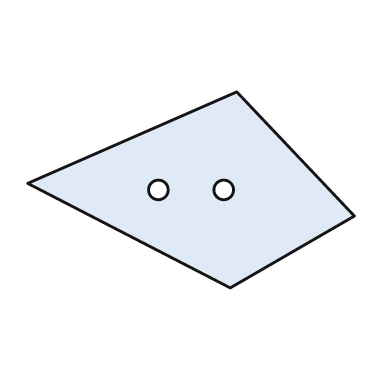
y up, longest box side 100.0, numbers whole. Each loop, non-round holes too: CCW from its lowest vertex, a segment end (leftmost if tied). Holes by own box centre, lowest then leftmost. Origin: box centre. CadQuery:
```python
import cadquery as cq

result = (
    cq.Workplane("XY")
    .moveTo(12.0, -30.0)
    .lineTo(50.0, -8.0)
    .lineTo(14.0, 30.0)
    .lineTo(-50.0, 2.0)
    .close()
    .moveTo(-10.0, 0.0)
    .circle(3.0)
    .moveTo(10.0, 0.0)
    .circle(3.0)
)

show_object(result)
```